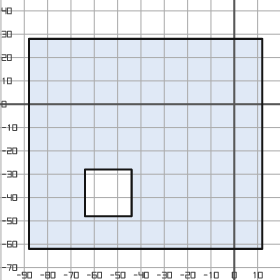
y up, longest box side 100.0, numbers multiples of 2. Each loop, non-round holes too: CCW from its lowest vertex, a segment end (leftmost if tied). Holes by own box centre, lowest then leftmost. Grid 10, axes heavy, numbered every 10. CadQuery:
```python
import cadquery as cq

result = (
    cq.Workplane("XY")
    .moveTo(-88.0, -62.0)
    .lineTo(12.0, -62.0)
    .lineTo(12.0, 28.0)
    .lineTo(-88.0, 28.0)
    .close()
    .moveTo(-64.0, -48.0)
    .lineTo(-44.0, -48.0)
    .lineTo(-44.0, -28.0)
    .lineTo(-64.0, -28.0)
    .close()
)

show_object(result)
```